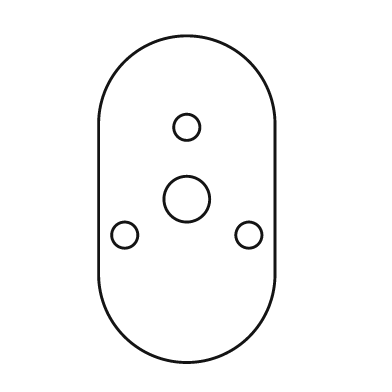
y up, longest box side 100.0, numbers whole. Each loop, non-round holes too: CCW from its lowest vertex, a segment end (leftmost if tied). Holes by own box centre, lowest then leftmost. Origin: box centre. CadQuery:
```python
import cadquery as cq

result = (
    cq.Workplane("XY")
    .moveTo(-27.0, -23.0)
    .threePointArc((0.0, -50.0), (27.0, -23.0))
    .lineTo(27.0, 23.0)
    .threePointArc((0.0, 50.0), (-27.0, 23.0))
    .close()
    .moveTo(-19.0, -11.0)
    .circle(4.0)
    .moveTo(19.0, -11.0)
    .circle(4.0)
    .moveTo(0.0, 0.0)
    .circle(7.0)
    .moveTo(0.0, 22.0)
    .circle(4.0)
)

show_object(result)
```